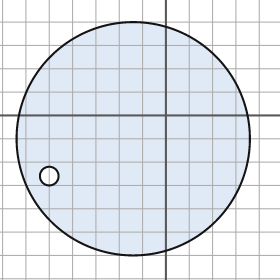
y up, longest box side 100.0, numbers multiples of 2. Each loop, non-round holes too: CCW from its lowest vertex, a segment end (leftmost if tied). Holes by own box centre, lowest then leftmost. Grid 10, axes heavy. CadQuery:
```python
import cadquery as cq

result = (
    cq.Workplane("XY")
    .moveTo(-14.0, -10.0)
    .circle(50.0)
    .moveTo(-50.0, -26.0)
    .circle(4.0)
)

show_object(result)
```